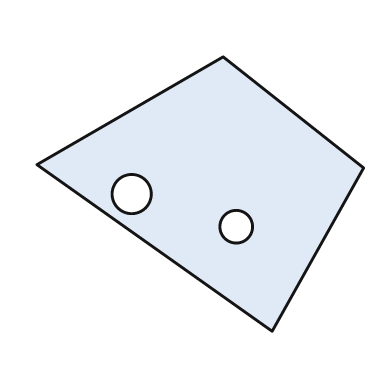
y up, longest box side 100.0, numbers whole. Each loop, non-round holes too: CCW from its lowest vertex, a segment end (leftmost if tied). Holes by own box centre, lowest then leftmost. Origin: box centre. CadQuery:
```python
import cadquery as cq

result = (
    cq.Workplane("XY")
    .moveTo(22.0, -42.0)
    .lineTo(50.0, 8.0)
    .lineTo(7.0, 42.0)
    .lineTo(-50.0, 9.0)
    .close()
    .moveTo(11.0, -10.0)
    .circle(5.0)
    .moveTo(-21.0, 0.0)
    .circle(6.0)
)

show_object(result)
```